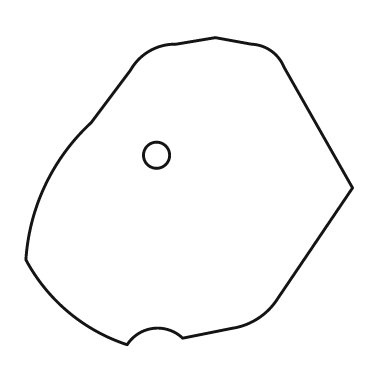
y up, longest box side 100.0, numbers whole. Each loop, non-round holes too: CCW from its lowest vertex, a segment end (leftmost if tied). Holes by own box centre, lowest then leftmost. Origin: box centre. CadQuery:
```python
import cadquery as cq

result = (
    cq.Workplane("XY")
    .moveTo(-19.0, -47.0)
    .threePointArc((-11.0, -42.0), (-2.0, -45.0))
    .lineTo(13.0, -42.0)
    .threePointArc((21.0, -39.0), (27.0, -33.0))
    .lineTo(50.0, 1.0)
    .lineTo(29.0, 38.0)
    .threePointArc((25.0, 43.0), (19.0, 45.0))
    .lineTo(8.0, 47.0)
    .lineTo(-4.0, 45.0)
    .threePointArc((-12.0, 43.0), (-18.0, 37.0))
    .lineTo(-30.0, 21.0)
    .threePointArc((-44.0, 2.0), (-50.0, -21.0))
    .threePointArc((-37.0, -37.0), (-19.0, -47.0))
    .close()
    .moveTo(-10.0, 11.0)
    .circle(4.0)
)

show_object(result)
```